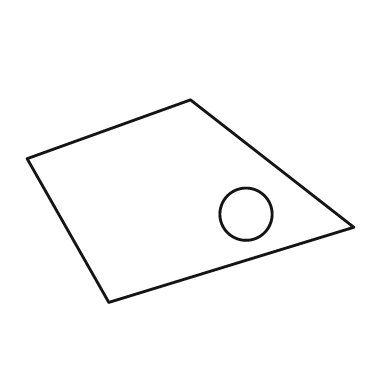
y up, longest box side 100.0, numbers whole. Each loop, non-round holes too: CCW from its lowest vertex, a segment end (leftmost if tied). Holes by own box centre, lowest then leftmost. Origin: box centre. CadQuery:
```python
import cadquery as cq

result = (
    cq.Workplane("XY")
    .moveTo(-25.0, -31.0)
    .lineTo(50.0, -8.0)
    .lineTo(0.0, 31.0)
    .lineTo(-50.0, 13.0)
    .close()
    .moveTo(17.0, -4.0)
    .circle(8.0)
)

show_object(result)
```